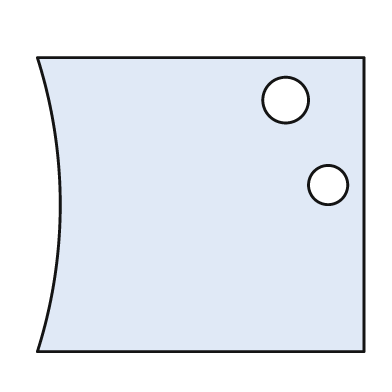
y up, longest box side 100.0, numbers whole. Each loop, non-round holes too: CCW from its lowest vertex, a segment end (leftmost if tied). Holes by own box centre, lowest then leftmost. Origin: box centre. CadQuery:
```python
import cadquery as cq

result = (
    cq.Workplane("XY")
    .moveTo(-50.0, -45.0)
    .lineTo(50.0, -45.0)
    .lineTo(50.0, 45.0)
    .lineTo(-50.0, 45.0)
    .threePointArc((-43.0, 0.0), (-50.0, -45.0))
    .close()
    .moveTo(39.0, 6.0)
    .circle(6.0)
    .moveTo(26.0, 32.0)
    .circle(7.0)
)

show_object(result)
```